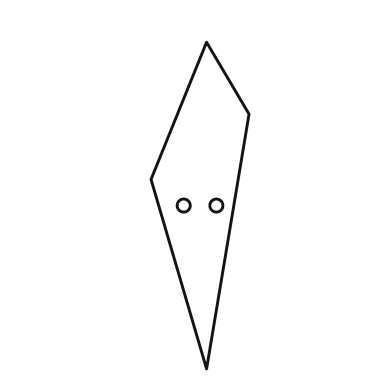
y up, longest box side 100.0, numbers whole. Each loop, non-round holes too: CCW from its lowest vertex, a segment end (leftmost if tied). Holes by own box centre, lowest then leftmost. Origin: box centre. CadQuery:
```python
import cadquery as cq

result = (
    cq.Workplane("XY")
    .moveTo(2.0, -50.0)
    .lineTo(15.0, 28.0)
    .lineTo(2.0, 50.0)
    .lineTo(-15.0, 8.0)
    .close()
    .moveTo(-5.0, 0.0)
    .circle(2.0)
    .moveTo(5.0, 0.0)
    .circle(2.0)
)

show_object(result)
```